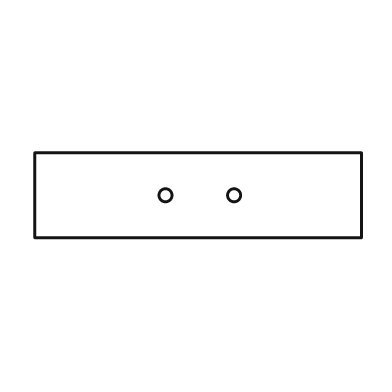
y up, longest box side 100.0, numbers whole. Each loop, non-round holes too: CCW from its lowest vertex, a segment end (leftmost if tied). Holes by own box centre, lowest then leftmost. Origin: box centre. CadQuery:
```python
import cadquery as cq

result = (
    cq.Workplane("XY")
    .moveTo(-50.0, -13.0)
    .lineTo(50.0, -13.0)
    .lineTo(50.0, 13.0)
    .lineTo(-50.0, 13.0)
    .close()
    .moveTo(-10.0, 0.0)
    .circle(2.0)
    .moveTo(11.0, 0.0)
    .circle(2.0)
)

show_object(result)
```